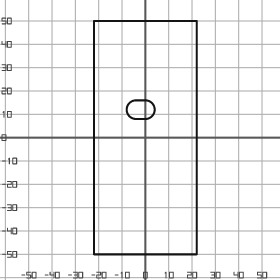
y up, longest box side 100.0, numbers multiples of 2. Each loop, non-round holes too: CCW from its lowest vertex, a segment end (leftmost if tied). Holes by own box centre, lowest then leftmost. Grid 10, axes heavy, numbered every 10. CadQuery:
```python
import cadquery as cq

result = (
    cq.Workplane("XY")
    .moveTo(-22.0, -50.0)
    .lineTo(22.0, -50.0)
    .lineTo(22.0, 50.0)
    .lineTo(-22.0, 50.0)
    .close()
    .moveTo(-4.0, 8.0)
    .lineTo(0.0, 8.0)
    .threePointArc((4.0, 12.0), (0.0, 16.0))
    .lineTo(-4.0, 16.0)
    .threePointArc((-8.0, 12.0), (-4.0, 8.0))
    .close()
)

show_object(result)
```